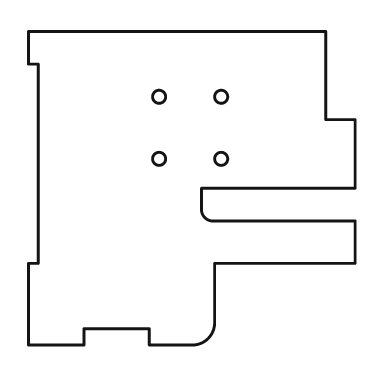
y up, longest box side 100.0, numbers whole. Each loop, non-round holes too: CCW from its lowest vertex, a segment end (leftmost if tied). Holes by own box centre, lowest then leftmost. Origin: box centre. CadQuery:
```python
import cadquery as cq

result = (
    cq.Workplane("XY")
    .moveTo(-50.0, -48.0)
    .lineTo(-33.0, -48.0)
    .lineTo(-33.0, -43.0)
    .lineTo(-13.0, -43.0)
    .lineTo(-13.0, -48.0)
    .lineTo(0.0, -48.0)
    .threePointArc((5.0, -46.0), (7.0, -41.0))
    .lineTo(7.0, -23.0)
    .lineTo(50.0, -23.0)
    .lineTo(50.0, -10.0)
    .lineTo(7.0, -10.0)
    .threePointArc((4.0, -9.0), (3.0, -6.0))
    .lineTo(3.0, 0.0)
    .lineTo(50.0, 0.0)
    .lineTo(50.0, 21.0)
    .lineTo(41.0, 21.0)
    .lineTo(41.0, 48.0)
    .lineTo(-50.0, 48.0)
    .lineTo(-50.0, 38.0)
    .lineTo(-47.0, 38.0)
    .lineTo(-47.0, -23.0)
    .lineTo(-50.0, -23.0)
    .close()
    .moveTo(-10.0, 9.0)
    .circle(2.0)
    .moveTo(9.0, 9.0)
    .circle(2.0)
    .moveTo(-10.0, 28.0)
    .circle(2.0)
    .moveTo(9.0, 28.0)
    .circle(2.0)
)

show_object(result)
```